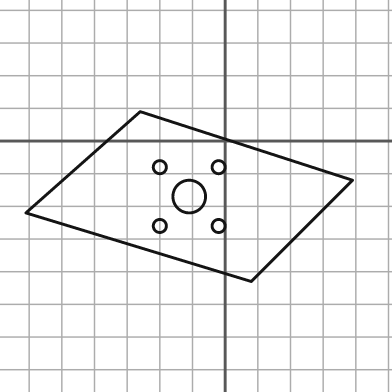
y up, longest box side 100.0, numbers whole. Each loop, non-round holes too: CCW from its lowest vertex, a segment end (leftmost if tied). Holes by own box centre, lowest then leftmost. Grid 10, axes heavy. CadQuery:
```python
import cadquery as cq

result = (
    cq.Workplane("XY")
    .moveTo(8.0, -43.0)
    .lineTo(39.0, -12.0)
    .lineTo(-26.0, 9.0)
    .lineTo(-61.0, -22.0)
    .close()
    .moveTo(-20.0, -26.0)
    .circle(2.0)
    .moveTo(-2.0, -26.0)
    .circle(2.0)
    .moveTo(-11.0, -17.0)
    .circle(5.0)
    .moveTo(-20.0, -8.0)
    .circle(2.0)
    .moveTo(-2.0, -8.0)
    .circle(2.0)
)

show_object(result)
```